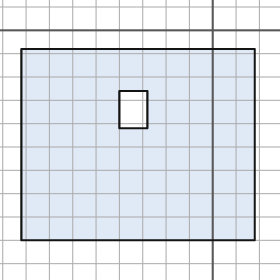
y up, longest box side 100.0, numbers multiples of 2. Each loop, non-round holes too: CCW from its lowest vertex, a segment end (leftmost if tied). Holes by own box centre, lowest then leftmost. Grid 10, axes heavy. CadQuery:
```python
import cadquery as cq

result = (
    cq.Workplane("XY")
    .moveTo(-82.0, -90.0)
    .lineTo(18.0, -90.0)
    .lineTo(18.0, -8.0)
    .lineTo(-82.0, -8.0)
    .close()
    .moveTo(-40.0, -42.0)
    .lineTo(-28.0, -42.0)
    .lineTo(-28.0, -26.0)
    .lineTo(-40.0, -26.0)
    .close()
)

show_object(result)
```